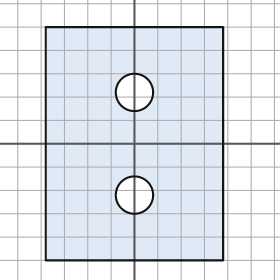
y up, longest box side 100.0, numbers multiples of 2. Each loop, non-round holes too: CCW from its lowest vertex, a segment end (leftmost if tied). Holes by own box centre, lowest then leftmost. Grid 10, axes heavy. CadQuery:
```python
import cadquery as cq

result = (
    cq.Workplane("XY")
    .moveTo(-38.0, -50.0)
    .lineTo(38.0, -50.0)
    .lineTo(38.0, 50.0)
    .lineTo(-38.0, 50.0)
    .close()
    .moveTo(0.0, -22.0)
    .circle(8.0)
    .moveTo(0.0, 22.0)
    .circle(8.0)
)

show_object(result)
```